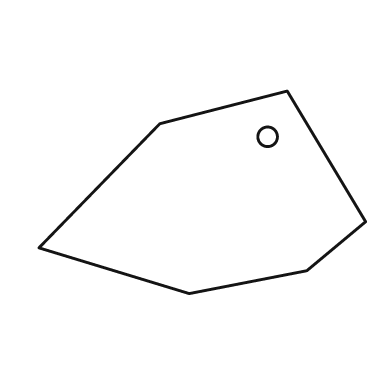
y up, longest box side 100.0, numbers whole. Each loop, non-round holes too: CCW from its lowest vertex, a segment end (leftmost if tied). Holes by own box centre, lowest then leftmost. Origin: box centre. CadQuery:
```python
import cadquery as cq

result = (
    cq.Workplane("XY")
    .moveTo(-4.0, -31.0)
    .lineTo(32.0, -24.0)
    .lineTo(50.0, -9.0)
    .lineTo(26.0, 31.0)
    .lineTo(-13.0, 21.0)
    .lineTo(-50.0, -17.0)
    .close()
    .moveTo(20.0, 17.0)
    .circle(3.0)
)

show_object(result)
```